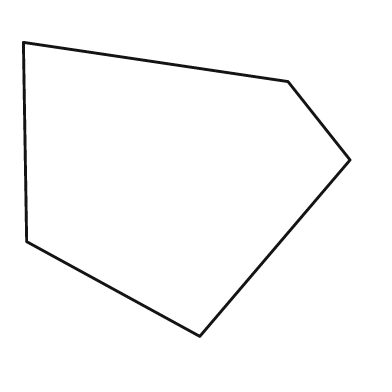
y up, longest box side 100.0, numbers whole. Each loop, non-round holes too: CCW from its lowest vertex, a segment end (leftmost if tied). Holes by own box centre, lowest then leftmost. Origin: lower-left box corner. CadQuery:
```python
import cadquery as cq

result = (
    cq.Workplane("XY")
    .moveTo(54.0, 0.0)
    .lineTo(100.0, 54.0)
    .lineTo(81.0, 78.0)
    .lineTo(0.0, 90.0)
    .lineTo(1.0, 29.0)
    .close()
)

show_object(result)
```